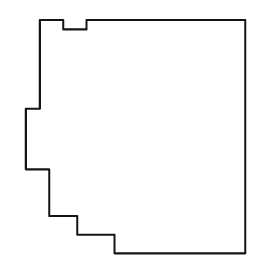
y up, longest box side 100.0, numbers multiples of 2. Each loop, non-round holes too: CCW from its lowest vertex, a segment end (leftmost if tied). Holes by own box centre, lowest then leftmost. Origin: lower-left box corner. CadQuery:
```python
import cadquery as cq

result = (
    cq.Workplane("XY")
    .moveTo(38.0, 0.0)
    .lineTo(94.0, 0.0)
    .lineTo(94.0, 100.0)
    .lineTo(26.0, 100.0)
    .lineTo(26.0, 96.0)
    .lineTo(16.0, 96.0)
    .lineTo(16.0, 100.0)
    .lineTo(6.0, 100.0)
    .lineTo(6.0, 62.0)
    .lineTo(0.0, 62.0)
    .lineTo(0.0, 36.0)
    .lineTo(10.0, 36.0)
    .lineTo(10.0, 16.0)
    .lineTo(22.0, 16.0)
    .lineTo(22.0, 8.0)
    .lineTo(38.0, 8.0)
    .close()
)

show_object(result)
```